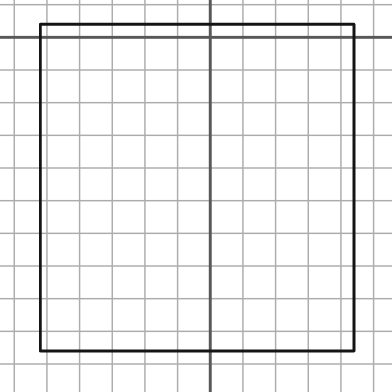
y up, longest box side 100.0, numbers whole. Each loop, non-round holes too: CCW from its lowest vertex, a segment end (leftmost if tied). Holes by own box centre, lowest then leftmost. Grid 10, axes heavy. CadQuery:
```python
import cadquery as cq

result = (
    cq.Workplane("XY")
    .moveTo(-52.0, -96.0)
    .lineTo(44.0, -96.0)
    .lineTo(44.0, 4.0)
    .lineTo(-52.0, 4.0)
    .close()
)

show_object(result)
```